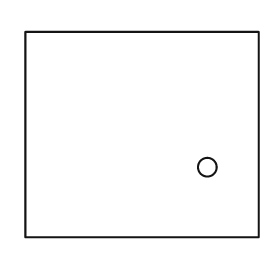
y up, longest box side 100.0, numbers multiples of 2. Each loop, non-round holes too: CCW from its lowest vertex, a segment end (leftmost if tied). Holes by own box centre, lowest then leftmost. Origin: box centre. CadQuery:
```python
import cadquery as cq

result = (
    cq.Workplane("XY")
    .moveTo(-50.0, -44.0)
    .lineTo(50.0, -44.0)
    .lineTo(50.0, 44.0)
    .lineTo(-50.0, 44.0)
    .close()
    .moveTo(28.0, -14.0)
    .circle(4.0)
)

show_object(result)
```